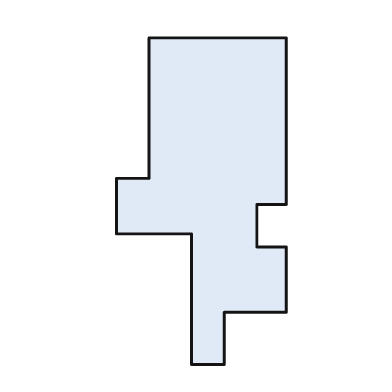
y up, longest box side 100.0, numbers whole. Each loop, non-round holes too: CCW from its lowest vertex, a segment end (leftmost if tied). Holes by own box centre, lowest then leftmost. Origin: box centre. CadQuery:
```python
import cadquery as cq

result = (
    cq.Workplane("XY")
    .moveTo(-3.0, -50.0)
    .lineTo(7.0, -50.0)
    .lineTo(7.0, -34.0)
    .lineTo(26.0, -34.0)
    .lineTo(26.0, -14.0)
    .lineTo(17.0, -14.0)
    .lineTo(17.0, -1.0)
    .lineTo(26.0, -1.0)
    .lineTo(26.0, 50.0)
    .lineTo(-16.0, 50.0)
    .lineTo(-16.0, 7.0)
    .lineTo(-26.0, 7.0)
    .lineTo(-26.0, -10.0)
    .lineTo(-3.0, -10.0)
    .close()
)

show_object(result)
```